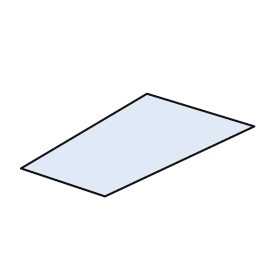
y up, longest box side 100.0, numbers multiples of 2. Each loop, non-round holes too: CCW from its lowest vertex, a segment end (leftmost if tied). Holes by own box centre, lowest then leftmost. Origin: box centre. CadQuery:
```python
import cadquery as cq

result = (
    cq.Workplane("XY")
    .moveTo(-14.0, -22.0)
    .lineTo(50.0, 8.0)
    .lineTo(4.0, 22.0)
    .lineTo(-50.0, -10.0)
    .close()
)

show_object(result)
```